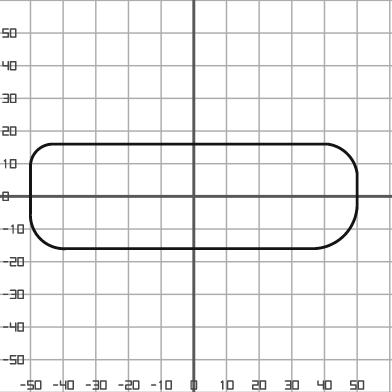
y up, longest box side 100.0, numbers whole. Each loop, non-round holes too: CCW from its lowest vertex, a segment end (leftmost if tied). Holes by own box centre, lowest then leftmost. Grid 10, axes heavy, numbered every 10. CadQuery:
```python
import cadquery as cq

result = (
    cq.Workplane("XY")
    .moveTo(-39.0, -16.0)
    .lineTo(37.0, -16.0)
    .threePointArc((46.0, -12.0), (50.0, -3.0))
    .lineTo(50.0, 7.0)
    .threePointArc((47.0, 13.0), (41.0, 16.0))
    .lineTo(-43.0, 16.0)
    .threePointArc((-48.0, 14.0), (-50.0, 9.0))
    .lineTo(-50.0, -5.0)
    .threePointArc((-47.0, -13.0), (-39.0, -16.0))
    .close()
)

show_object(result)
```